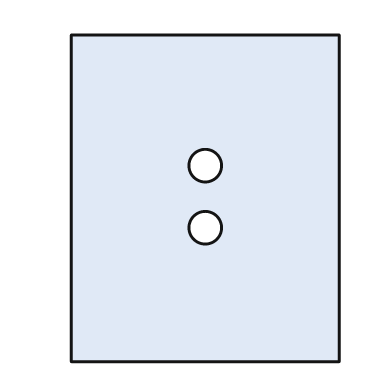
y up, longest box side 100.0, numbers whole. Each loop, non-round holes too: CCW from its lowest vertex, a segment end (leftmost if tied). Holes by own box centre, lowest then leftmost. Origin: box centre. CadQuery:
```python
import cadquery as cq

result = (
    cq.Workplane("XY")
    .moveTo(-41.0, -50.0)
    .lineTo(41.0, -50.0)
    .lineTo(41.0, 50.0)
    .lineTo(-41.0, 50.0)
    .close()
    .moveTo(0.0, -9.0)
    .circle(5.0)
    .moveTo(0.0, 10.0)
    .circle(5.0)
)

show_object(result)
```